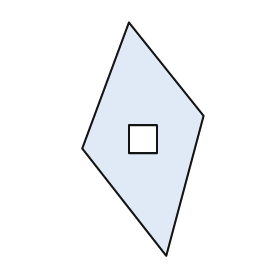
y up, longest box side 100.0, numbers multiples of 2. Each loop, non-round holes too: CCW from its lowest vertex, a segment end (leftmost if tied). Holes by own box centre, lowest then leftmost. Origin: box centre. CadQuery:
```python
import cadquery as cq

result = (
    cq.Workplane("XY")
    .moveTo(10.0, -50.0)
    .lineTo(26.0, 10.0)
    .lineTo(-6.0, 50.0)
    .lineTo(-26.0, -4.0)
    .close()
    .moveTo(-6.0, -6.0)
    .lineTo(6.0, -6.0)
    .lineTo(6.0, 6.0)
    .lineTo(-6.0, 6.0)
    .close()
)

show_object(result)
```